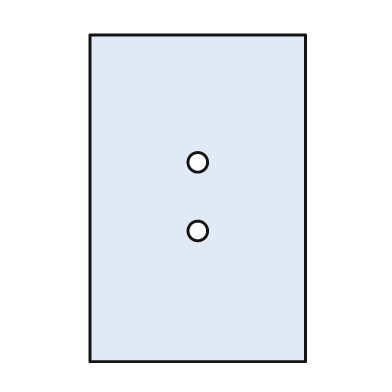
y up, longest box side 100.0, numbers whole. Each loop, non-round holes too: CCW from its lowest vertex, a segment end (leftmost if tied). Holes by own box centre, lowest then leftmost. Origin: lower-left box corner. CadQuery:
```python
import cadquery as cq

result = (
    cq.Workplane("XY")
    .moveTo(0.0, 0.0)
    .lineTo(66.0, 0.0)
    .lineTo(66.0, 100.0)
    .lineTo(0.0, 100.0)
    .close()
    .moveTo(33.0, 40.0)
    .circle(3.0)
    .moveTo(33.0, 61.0)
    .circle(3.0)
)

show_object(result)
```